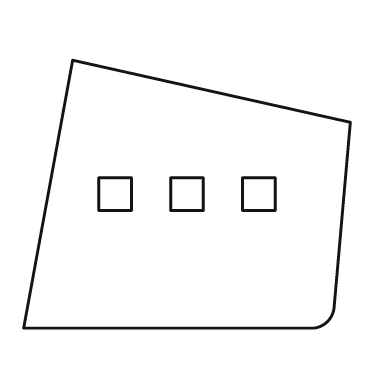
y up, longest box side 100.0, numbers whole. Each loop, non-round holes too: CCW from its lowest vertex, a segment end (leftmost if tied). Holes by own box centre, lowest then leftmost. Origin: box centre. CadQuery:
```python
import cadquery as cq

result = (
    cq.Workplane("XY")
    .moveTo(-50.0, -41.0)
    .lineTo(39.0, -41.0)
    .threePointArc((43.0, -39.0), (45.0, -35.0))
    .lineTo(50.0, 22.0)
    .lineTo(-35.0, 41.0)
    .close()
    .moveTo(-27.0, -5.0)
    .lineTo(-17.0, -5.0)
    .lineTo(-17.0, 5.0)
    .lineTo(-27.0, 5.0)
    .close()
    .moveTo(-5.0, -5.0)
    .lineTo(5.0, -5.0)
    .lineTo(5.0, 5.0)
    .lineTo(-5.0, 5.0)
    .close()
    .moveTo(17.0, -5.0)
    .lineTo(27.0, -5.0)
    .lineTo(27.0, 5.0)
    .lineTo(17.0, 5.0)
    .close()
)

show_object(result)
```